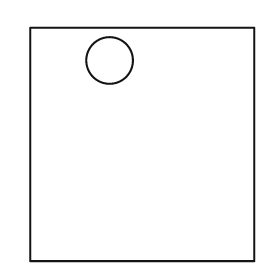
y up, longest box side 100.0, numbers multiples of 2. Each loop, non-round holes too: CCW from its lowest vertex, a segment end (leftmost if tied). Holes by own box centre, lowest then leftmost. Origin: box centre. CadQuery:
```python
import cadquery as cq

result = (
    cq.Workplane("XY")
    .moveTo(-48.0, -50.0)
    .lineTo(48.0, -50.0)
    .lineTo(48.0, 50.0)
    .lineTo(-48.0, 50.0)
    .close()
    .moveTo(-14.0, 36.0)
    .circle(10.0)
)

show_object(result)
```